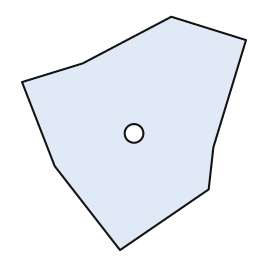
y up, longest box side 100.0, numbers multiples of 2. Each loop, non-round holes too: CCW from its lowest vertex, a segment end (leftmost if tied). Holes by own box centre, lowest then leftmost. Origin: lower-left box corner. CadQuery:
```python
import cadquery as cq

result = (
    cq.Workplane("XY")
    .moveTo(42.0, 0.0)
    .lineTo(80.0, 26.0)
    .lineTo(82.0, 44.0)
    .lineTo(96.0, 90.0)
    .lineTo(64.0, 100.0)
    .lineTo(26.0, 80.0)
    .lineTo(0.0, 72.0)
    .lineTo(14.0, 36.0)
    .close()
    .moveTo(48.0, 50.0)
    .circle(4.0)
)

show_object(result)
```